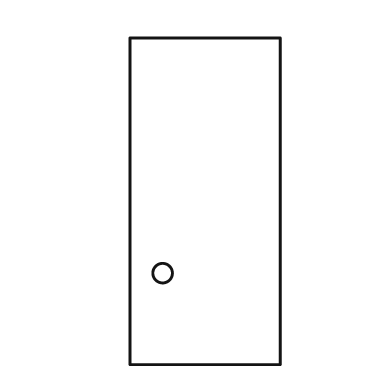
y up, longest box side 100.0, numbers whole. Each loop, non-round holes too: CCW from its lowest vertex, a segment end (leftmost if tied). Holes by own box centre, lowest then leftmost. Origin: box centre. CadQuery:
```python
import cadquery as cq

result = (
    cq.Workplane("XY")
    .moveTo(-23.0, -50.0)
    .lineTo(23.0, -50.0)
    .lineTo(23.0, 50.0)
    .lineTo(-23.0, 50.0)
    .close()
    .moveTo(-13.0, -22.0)
    .circle(3.0)
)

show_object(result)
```